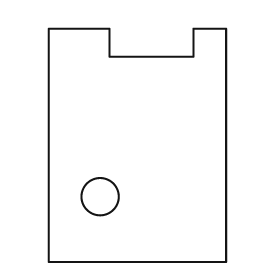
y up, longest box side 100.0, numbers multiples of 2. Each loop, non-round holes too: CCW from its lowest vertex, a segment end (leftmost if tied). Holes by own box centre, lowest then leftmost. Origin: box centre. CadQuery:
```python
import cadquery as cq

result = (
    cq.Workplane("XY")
    .moveTo(-38.0, -50.0)
    .lineTo(38.0, -50.0)
    .lineTo(38.0, 50.0)
    .lineTo(24.0, 50.0)
    .lineTo(24.0, 38.0)
    .lineTo(-12.0, 38.0)
    .lineTo(-12.0, 50.0)
    .lineTo(-38.0, 50.0)
    .close()
    .moveTo(-16.0, -22.0)
    .circle(8.0)
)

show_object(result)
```